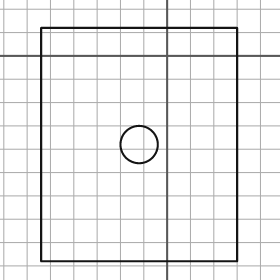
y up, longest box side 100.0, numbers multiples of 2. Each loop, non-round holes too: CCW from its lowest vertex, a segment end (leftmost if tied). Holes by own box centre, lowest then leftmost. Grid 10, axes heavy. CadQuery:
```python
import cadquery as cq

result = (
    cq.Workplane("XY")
    .moveTo(-54.0, -88.0)
    .lineTo(30.0, -88.0)
    .lineTo(30.0, 12.0)
    .lineTo(-54.0, 12.0)
    .close()
    .moveTo(-12.0, -38.0)
    .circle(8.0)
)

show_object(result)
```